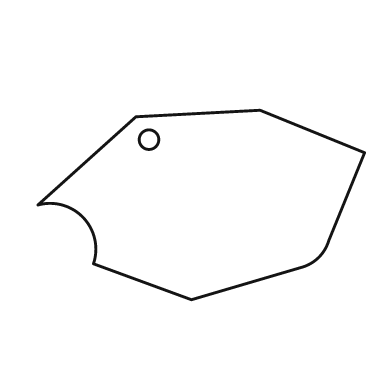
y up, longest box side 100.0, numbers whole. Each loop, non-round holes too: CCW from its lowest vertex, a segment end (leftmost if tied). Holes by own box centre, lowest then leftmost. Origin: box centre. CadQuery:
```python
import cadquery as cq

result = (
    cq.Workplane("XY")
    .moveTo(-3.0, -29.0)
    .lineTo(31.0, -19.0)
    .threePointArc((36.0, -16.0), (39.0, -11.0))
    .lineTo(50.0, 16.0)
    .lineTo(18.0, 29.0)
    .lineTo(-20.0, 27.0)
    .lineTo(-50.0, 0.0)
    .threePointArc((-36.0, -4.0), (-33.0, -18.0))
    .close()
    .moveTo(-16.0, 20.0)
    .circle(3.0)
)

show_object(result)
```